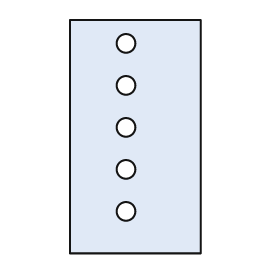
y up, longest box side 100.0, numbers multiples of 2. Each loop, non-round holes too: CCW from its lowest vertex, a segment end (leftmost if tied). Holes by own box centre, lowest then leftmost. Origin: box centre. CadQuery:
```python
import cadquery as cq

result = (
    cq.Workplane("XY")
    .moveTo(-28.0, -50.0)
    .lineTo(28.0, -50.0)
    .lineTo(28.0, 50.0)
    .lineTo(-28.0, 50.0)
    .close()
    .moveTo(-4.0, -32.0)
    .circle(4.0)
    .moveTo(-4.0, -14.0)
    .circle(4.0)
    .moveTo(-4.0, 4.0)
    .circle(4.0)
    .moveTo(-4.0, 22.0)
    .circle(4.0)
    .moveTo(-4.0, 40.0)
    .circle(4.0)
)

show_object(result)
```